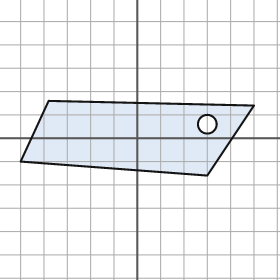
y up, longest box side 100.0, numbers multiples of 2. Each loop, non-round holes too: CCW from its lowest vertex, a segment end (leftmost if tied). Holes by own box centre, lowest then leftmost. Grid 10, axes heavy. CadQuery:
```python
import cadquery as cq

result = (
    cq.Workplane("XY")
    .moveTo(30.0, -16.0)
    .lineTo(50.0, 14.0)
    .lineTo(-38.0, 16.0)
    .lineTo(-50.0, -10.0)
    .close()
    .moveTo(30.0, 6.0)
    .circle(4.0)
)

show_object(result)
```